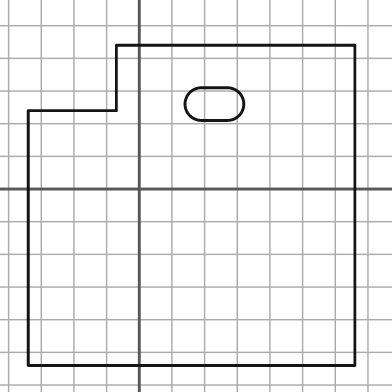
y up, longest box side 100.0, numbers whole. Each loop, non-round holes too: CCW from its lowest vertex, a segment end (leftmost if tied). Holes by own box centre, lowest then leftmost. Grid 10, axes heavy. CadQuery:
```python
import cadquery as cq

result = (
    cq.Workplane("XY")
    .moveTo(-34.0, -54.0)
    .lineTo(66.0, -54.0)
    .lineTo(66.0, 44.0)
    .lineTo(-7.0, 44.0)
    .lineTo(-7.0, 24.0)
    .lineTo(-34.0, 24.0)
    .close()
    .moveTo(19.0, 21.0)
    .lineTo(27.0, 21.0)
    .threePointArc((32.0, 26.0), (27.0, 31.0))
    .lineTo(19.0, 31.0)
    .threePointArc((14.0, 26.0), (19.0, 21.0))
    .close()
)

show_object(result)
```